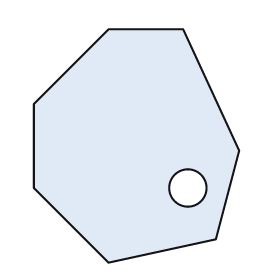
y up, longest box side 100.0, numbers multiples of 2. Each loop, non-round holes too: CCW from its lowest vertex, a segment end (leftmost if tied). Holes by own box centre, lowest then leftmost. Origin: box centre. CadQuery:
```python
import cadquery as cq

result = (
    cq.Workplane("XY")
    .moveTo(-12.0, -50.0)
    .lineTo(34.0, -40.0)
    .lineTo(44.0, -2.0)
    .lineTo(20.0, 50.0)
    .lineTo(-12.0, 50.0)
    .lineTo(-44.0, 18.0)
    .lineTo(-44.0, -18.0)
    .close()
    .moveTo(22.0, -18.0)
    .circle(8.0)
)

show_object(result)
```